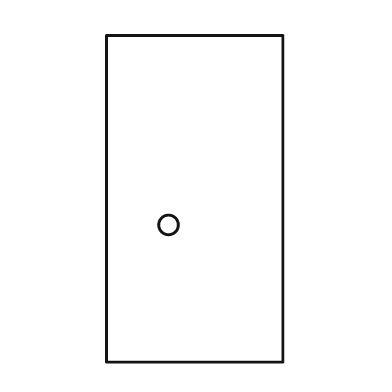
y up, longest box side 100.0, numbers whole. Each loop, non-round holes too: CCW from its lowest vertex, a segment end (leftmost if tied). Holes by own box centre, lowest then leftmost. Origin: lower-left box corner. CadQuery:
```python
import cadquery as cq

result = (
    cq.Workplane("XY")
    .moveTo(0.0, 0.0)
    .lineTo(54.0, 0.0)
    .lineTo(54.0, 100.0)
    .lineTo(0.0, 100.0)
    .close()
    .moveTo(19.0, 42.0)
    .circle(3.0)
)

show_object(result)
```